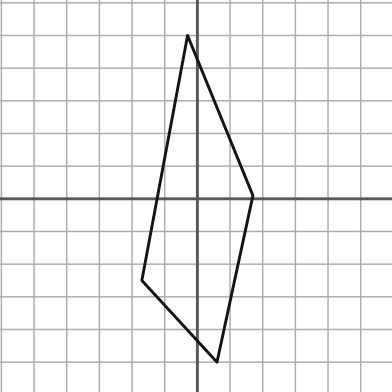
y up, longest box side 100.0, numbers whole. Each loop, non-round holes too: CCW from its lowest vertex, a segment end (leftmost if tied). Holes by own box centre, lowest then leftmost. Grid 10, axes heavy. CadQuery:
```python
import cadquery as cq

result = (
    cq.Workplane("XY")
    .moveTo(6.0, -50.0)
    .lineTo(17.0, 1.0)
    .lineTo(-3.0, 50.0)
    .lineTo(-17.0, -25.0)
    .close()
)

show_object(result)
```